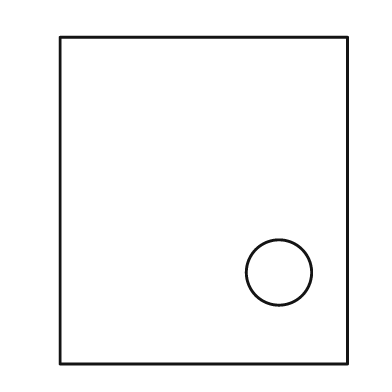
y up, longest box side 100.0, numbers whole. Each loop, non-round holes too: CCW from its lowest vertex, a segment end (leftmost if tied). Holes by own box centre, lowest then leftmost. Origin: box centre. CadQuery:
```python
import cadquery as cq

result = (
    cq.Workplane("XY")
    .moveTo(-44.0, -50.0)
    .lineTo(44.0, -50.0)
    .lineTo(44.0, 50.0)
    .lineTo(-44.0, 50.0)
    .close()
    .moveTo(23.0, -22.0)
    .circle(10.0)
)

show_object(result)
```